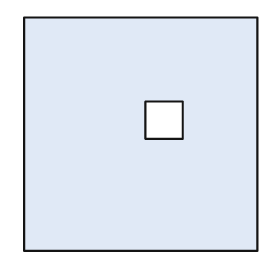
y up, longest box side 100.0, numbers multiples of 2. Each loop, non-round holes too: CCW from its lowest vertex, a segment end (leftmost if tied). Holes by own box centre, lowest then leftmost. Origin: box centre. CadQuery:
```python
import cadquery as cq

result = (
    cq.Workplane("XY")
    .moveTo(-50.0, -50.0)
    .lineTo(50.0, -50.0)
    .lineTo(50.0, 50.0)
    .lineTo(-50.0, 50.0)
    .close()
    .moveTo(2.0, -2.0)
    .lineTo(18.0, -2.0)
    .lineTo(18.0, 14.0)
    .lineTo(2.0, 14.0)
    .close()
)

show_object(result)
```